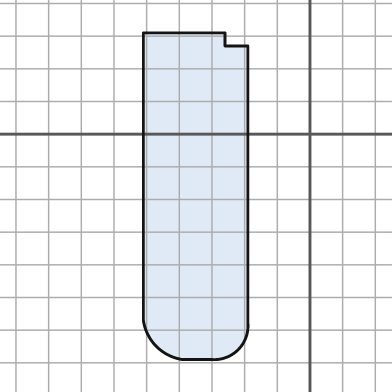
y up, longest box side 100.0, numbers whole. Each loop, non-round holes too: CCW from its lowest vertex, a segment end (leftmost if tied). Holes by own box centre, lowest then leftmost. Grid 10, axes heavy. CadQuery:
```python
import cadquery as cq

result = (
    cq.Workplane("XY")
    .moveTo(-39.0, -69.0)
    .lineTo(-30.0, -69.0)
    .threePointArc((-22.0, -66.0), (-19.0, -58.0))
    .lineTo(-19.0, 27.0)
    .lineTo(-26.0, 27.0)
    .lineTo(-26.0, 31.0)
    .lineTo(-51.0, 31.0)
    .lineTo(-51.0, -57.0)
    .threePointArc((-47.0, -65.0), (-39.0, -69.0))
    .close()
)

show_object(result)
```